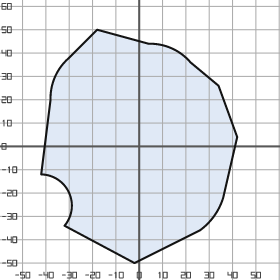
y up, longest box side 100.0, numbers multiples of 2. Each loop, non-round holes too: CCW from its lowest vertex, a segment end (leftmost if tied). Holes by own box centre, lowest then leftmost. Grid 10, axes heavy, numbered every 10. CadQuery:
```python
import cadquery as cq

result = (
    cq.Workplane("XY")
    .moveTo(-2.0, -50.0)
    .lineTo(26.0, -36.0)
    .threePointArc((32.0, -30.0), (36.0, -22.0))
    .lineTo(42.0, 4.0)
    .lineTo(34.0, 26.0)
    .lineTo(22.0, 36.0)
    .threePointArc((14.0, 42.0), (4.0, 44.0))
    .lineTo(-18.0, 50.0)
    .lineTo(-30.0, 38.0)
    .threePointArc((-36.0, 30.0), (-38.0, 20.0))
    .lineTo(-42.0, -12.0)
    .threePointArc((-30.0, -20.0), (-32.0, -34.0))
    .close()
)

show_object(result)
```